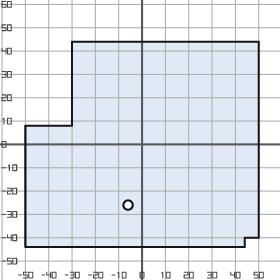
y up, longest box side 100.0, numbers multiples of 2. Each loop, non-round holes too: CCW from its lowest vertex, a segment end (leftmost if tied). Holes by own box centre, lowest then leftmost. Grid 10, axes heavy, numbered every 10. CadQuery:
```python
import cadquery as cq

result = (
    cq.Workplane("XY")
    .moveTo(-50.0, -44.0)
    .lineTo(44.0, -44.0)
    .lineTo(44.0, -40.0)
    .lineTo(50.0, -40.0)
    .lineTo(50.0, 44.0)
    .lineTo(-30.0, 44.0)
    .lineTo(-30.0, 8.0)
    .lineTo(-50.0, 8.0)
    .close()
    .moveTo(-6.0, -26.0)
    .circle(2.0)
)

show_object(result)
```